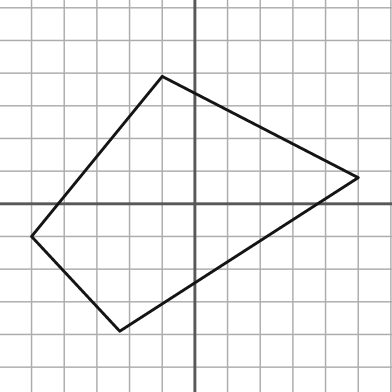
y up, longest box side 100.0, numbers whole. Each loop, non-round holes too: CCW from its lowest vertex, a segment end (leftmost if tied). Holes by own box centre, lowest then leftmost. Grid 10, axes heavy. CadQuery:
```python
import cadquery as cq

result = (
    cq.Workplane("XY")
    .moveTo(-23.0, -39.0)
    .lineTo(50.0, 8.0)
    .lineTo(-10.0, 39.0)
    .lineTo(-50.0, -10.0)
    .close()
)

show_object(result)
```